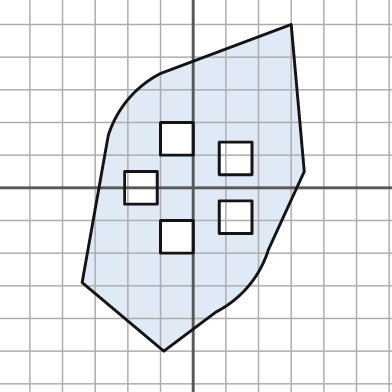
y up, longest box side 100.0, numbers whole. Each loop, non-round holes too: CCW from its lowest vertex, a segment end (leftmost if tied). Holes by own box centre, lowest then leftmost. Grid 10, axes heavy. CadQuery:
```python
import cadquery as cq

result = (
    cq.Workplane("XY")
    .moveTo(-9.0, -50.0)
    .lineTo(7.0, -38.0)
    .threePointArc((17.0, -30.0), (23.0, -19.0))
    .lineTo(34.0, 5.0)
    .lineTo(30.0, 50.0)
    .lineTo(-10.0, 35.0)
    .threePointArc((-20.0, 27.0), (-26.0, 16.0))
    .lineTo(-34.0, -29.0)
    .close()
    .moveTo(-10.0, -20.0)
    .lineTo(0.0, -20.0)
    .lineTo(0.0, -10.0)
    .lineTo(-10.0, -10.0)
    .close()
    .moveTo(8.0, -14.0)
    .lineTo(18.0, -14.0)
    .lineTo(18.0, -4.0)
    .lineTo(8.0, -4.0)
    .close()
    .moveTo(-21.0, -5.0)
    .lineTo(-11.0, -5.0)
    .lineTo(-11.0, 5.0)
    .lineTo(-21.0, 5.0)
    .close()
    .moveTo(8.0, 4.0)
    .lineTo(18.0, 4.0)
    .lineTo(18.0, 14.0)
    .lineTo(8.0, 14.0)
    .close()
    .moveTo(-10.0, 10.0)
    .lineTo(0.0, 10.0)
    .lineTo(0.0, 20.0)
    .lineTo(-10.0, 20.0)
    .close()
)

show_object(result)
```